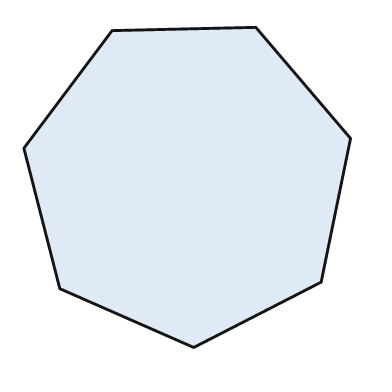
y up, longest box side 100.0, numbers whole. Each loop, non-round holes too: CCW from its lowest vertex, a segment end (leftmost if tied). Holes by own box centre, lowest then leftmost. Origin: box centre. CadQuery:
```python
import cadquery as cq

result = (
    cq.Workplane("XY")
    .moveTo(2.0, -49.0)
    .lineTo(41.0, -29.0)
    .lineTo(50.0, 15.0)
    .lineTo(21.0, 49.0)
    .lineTo(-23.0, 48.0)
    .lineTo(-50.0, 12.0)
    .lineTo(-39.0, -31.0)
    .close()
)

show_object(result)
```